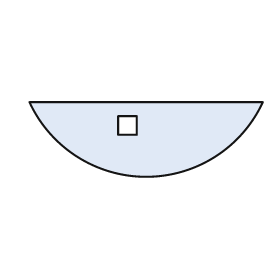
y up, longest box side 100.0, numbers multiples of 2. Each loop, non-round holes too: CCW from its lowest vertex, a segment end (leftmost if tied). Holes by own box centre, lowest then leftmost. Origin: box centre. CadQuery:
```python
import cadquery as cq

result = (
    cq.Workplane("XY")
    .moveTo(-50.0, 16.0)
    .threePointArc((0.0, -16.0), (50.0, 16.0))
    .close()
    .moveTo(-12.0, 2.0)
    .lineTo(-4.0, 2.0)
    .lineTo(-4.0, 10.0)
    .lineTo(-12.0, 10.0)
    .close()
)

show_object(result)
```